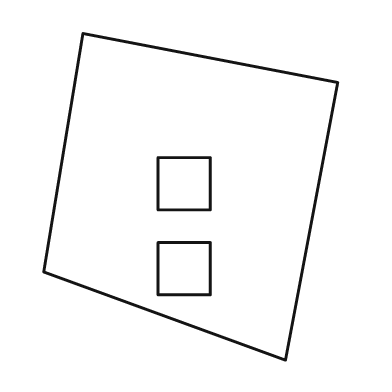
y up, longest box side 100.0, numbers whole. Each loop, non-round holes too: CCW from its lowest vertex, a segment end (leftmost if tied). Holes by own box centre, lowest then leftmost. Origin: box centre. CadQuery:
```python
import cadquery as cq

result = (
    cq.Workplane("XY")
    .moveTo(29.0, -50.0)
    .lineTo(45.0, 35.0)
    .lineTo(-33.0, 50.0)
    .lineTo(-45.0, -23.0)
    .close()
    .moveTo(-10.0, -30.0)
    .lineTo(6.0, -30.0)
    .lineTo(6.0, -14.0)
    .lineTo(-10.0, -14.0)
    .close()
    .moveTo(-10.0, -4.0)
    .lineTo(6.0, -4.0)
    .lineTo(6.0, 12.0)
    .lineTo(-10.0, 12.0)
    .close()
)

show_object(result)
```